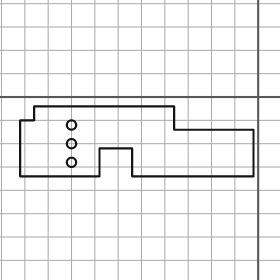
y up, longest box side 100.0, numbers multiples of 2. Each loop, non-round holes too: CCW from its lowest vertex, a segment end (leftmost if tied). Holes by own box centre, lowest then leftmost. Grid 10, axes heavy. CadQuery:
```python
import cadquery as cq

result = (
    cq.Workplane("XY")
    .moveTo(-102.0, -34.0)
    .lineTo(-68.0, -34.0)
    .lineTo(-68.0, -22.0)
    .lineTo(-54.0, -22.0)
    .lineTo(-54.0, -34.0)
    .lineTo(-2.0, -34.0)
    .lineTo(-2.0, -14.0)
    .lineTo(-36.0, -14.0)
    .lineTo(-36.0, -4.0)
    .lineTo(-96.0, -4.0)
    .lineTo(-96.0, -10.0)
    .lineTo(-102.0, -10.0)
    .close()
    .moveTo(-80.0, -28.0)
    .circle(2.0)
    .moveTo(-80.0, -20.0)
    .circle(2.0)
    .moveTo(-80.0, -12.0)
    .circle(2.0)
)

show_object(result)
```